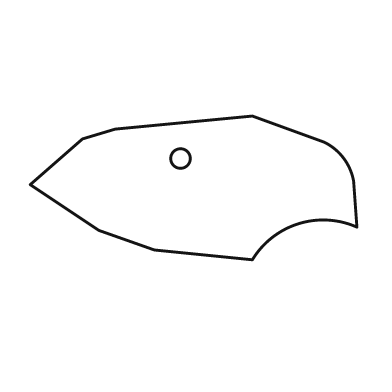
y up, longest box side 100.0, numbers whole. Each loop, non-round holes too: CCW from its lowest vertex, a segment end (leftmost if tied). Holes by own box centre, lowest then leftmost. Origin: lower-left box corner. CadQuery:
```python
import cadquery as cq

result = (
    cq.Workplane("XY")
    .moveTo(68.0, 0.0)
    .threePointArc((82.0, 11.0), (100.0, 10.0))
    .lineTo(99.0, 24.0)
    .threePointArc((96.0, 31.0), (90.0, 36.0))
    .lineTo(68.0, 44.0)
    .lineTo(26.0, 40.0)
    .lineTo(16.0, 37.0)
    .lineTo(0.0, 23.0)
    .lineTo(21.0, 9.0)
    .lineTo(38.0, 3.0)
    .close()
    .moveTo(46.0, 31.0)
    .circle(3.0)
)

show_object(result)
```